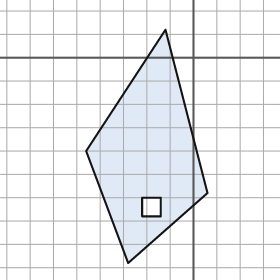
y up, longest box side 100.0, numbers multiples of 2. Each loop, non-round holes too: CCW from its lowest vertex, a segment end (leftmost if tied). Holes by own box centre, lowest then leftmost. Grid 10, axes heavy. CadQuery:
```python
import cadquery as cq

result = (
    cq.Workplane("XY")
    .moveTo(-28.0, -88.0)
    .lineTo(6.0, -58.0)
    .lineTo(-12.0, 12.0)
    .lineTo(-46.0, -40.0)
    .close()
    .moveTo(-22.0, -68.0)
    .lineTo(-14.0, -68.0)
    .lineTo(-14.0, -60.0)
    .lineTo(-22.0, -60.0)
    .close()
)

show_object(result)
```